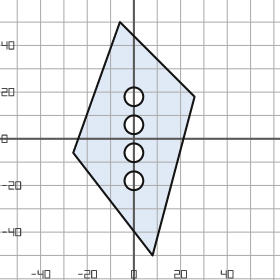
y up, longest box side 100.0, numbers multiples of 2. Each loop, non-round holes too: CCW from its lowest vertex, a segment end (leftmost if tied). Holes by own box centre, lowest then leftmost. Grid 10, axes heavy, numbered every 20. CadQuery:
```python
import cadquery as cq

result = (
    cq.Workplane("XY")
    .moveTo(8.0, -50.0)
    .lineTo(26.0, 18.0)
    .lineTo(-6.0, 50.0)
    .lineTo(-26.0, -6.0)
    .close()
    .moveTo(0.0, -18.0)
    .circle(4.0)
    .moveTo(0.0, -6.0)
    .circle(4.0)
    .moveTo(0.0, 6.0)
    .circle(4.0)
    .moveTo(0.0, 18.0)
    .circle(4.0)
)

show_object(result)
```